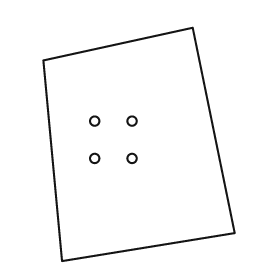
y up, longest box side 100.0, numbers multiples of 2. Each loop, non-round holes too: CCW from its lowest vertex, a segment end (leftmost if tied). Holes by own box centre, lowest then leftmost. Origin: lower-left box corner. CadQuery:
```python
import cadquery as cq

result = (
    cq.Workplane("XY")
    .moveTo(8.0, 0.0)
    .lineTo(82.0, 12.0)
    .lineTo(64.0, 100.0)
    .lineTo(0.0, 86.0)
    .close()
    .moveTo(22.0, 44.0)
    .circle(2.0)
    .moveTo(38.0, 44.0)
    .circle(2.0)
    .moveTo(22.0, 60.0)
    .circle(2.0)
    .moveTo(38.0, 60.0)
    .circle(2.0)
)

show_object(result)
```